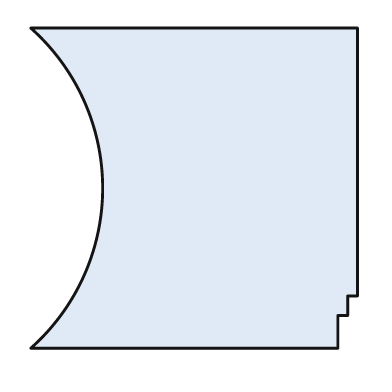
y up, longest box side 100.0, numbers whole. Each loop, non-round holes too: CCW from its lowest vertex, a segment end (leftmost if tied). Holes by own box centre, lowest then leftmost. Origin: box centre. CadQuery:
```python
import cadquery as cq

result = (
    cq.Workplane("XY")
    .moveTo(-50.0, -49.0)
    .lineTo(44.0, -49.0)
    .lineTo(44.0, -39.0)
    .lineTo(47.0, -39.0)
    .lineTo(47.0, -33.0)
    .lineTo(50.0, -33.0)
    .lineTo(50.0, 49.0)
    .lineTo(-50.0, 49.0)
    .threePointArc((-28.0, 0.0), (-50.0, -49.0))
    .close()
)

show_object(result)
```